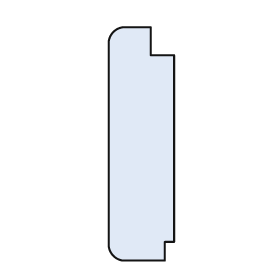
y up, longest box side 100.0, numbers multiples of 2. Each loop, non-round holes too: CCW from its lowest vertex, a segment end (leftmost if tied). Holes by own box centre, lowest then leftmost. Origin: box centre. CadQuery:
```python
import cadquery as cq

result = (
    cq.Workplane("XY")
    .moveTo(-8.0, -50.0)
    .lineTo(10.0, -50.0)
    .lineTo(10.0, -42.0)
    .lineTo(14.0, -42.0)
    .lineTo(14.0, 38.0)
    .lineTo(4.0, 38.0)
    .lineTo(4.0, 50.0)
    .lineTo(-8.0, 50.0)
    .threePointArc((-12.0, 48.0), (-14.0, 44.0))
    .lineTo(-14.0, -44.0)
    .threePointArc((-12.0, -48.0), (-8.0, -50.0))
    .close()
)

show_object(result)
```